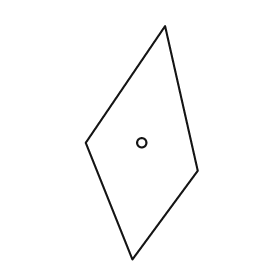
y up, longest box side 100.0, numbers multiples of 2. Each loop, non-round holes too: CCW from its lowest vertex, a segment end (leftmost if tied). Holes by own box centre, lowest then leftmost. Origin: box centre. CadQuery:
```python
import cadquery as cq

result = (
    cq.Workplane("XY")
    .moveTo(-4.0, -50.0)
    .lineTo(24.0, -12.0)
    .lineTo(10.0, 50.0)
    .lineTo(-24.0, 0.0)
    .close()
    .moveTo(0.0, 0.0)
    .circle(2.0)
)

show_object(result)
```